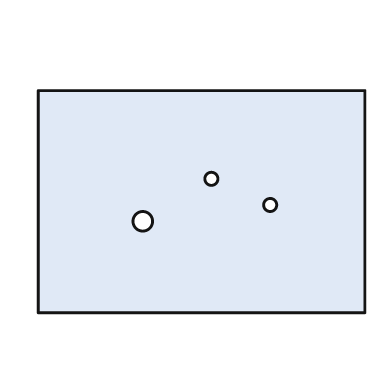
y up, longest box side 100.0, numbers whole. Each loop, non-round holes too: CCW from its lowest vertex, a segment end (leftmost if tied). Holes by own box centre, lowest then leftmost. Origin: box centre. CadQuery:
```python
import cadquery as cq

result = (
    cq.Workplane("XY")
    .moveTo(-50.0, -34.0)
    .lineTo(50.0, -34.0)
    .lineTo(50.0, 34.0)
    .lineTo(-50.0, 34.0)
    .close()
    .moveTo(-18.0, -6.0)
    .circle(3.0)
    .moveTo(21.0, -1.0)
    .circle(2.0)
    .moveTo(3.0, 7.0)
    .circle(2.0)
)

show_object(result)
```